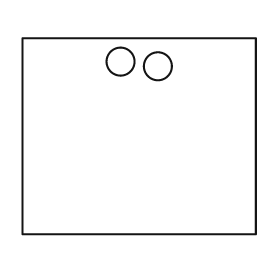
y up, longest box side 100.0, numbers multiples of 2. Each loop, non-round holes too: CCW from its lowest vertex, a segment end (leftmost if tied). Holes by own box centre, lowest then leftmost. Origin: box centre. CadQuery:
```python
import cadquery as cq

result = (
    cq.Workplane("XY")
    .moveTo(-50.0, -42.0)
    .lineTo(50.0, -42.0)
    .lineTo(50.0, 42.0)
    .lineTo(-50.0, 42.0)
    .close()
    .moveTo(8.0, 30.0)
    .circle(6.0)
    .moveTo(-8.0, 32.0)
    .circle(6.0)
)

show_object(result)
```